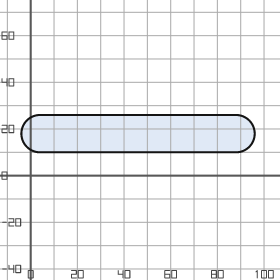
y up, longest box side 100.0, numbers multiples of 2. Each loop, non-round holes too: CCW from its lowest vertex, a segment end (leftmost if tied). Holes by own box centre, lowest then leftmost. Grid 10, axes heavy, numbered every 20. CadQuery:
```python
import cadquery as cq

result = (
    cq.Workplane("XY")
    .moveTo(4.0, 10.0)
    .lineTo(88.0, 10.0)
    .threePointArc((96.0, 18.0), (88.0, 26.0))
    .lineTo(4.0, 26.0)
    .threePointArc((-4.0, 18.0), (4.0, 10.0))
    .close()
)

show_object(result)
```